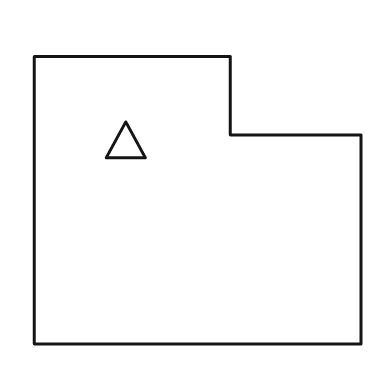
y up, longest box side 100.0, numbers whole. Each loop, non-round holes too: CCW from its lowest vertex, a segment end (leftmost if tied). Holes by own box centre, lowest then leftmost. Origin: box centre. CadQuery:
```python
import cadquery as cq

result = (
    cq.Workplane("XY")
    .moveTo(-50.0, -44.0)
    .lineTo(50.0, -44.0)
    .lineTo(50.0, 20.0)
    .lineTo(10.0, 20.0)
    .lineTo(10.0, 44.0)
    .lineTo(-50.0, 44.0)
    .close()
    .moveTo(-28.0, 13.0)
    .lineTo(-16.0, 13.0)
    .lineTo(-22.0, 24.0)
    .close()
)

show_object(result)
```